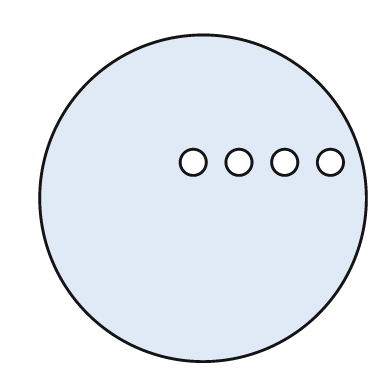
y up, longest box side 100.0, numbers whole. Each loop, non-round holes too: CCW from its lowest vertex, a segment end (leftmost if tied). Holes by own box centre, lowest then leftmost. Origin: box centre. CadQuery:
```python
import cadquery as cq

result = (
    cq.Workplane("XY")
    .moveTo(0.0, 0.0)
    .circle(50.0)
    .moveTo(-3.0, 11.0)
    .circle(4.0)
    .moveTo(11.0, 11.0)
    .circle(4.0)
    .moveTo(25.0, 11.0)
    .circle(4.0)
    .moveTo(39.0, 11.0)
    .circle(4.0)
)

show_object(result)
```